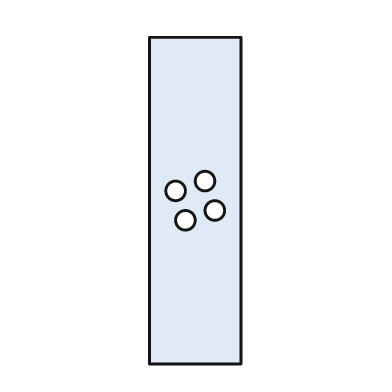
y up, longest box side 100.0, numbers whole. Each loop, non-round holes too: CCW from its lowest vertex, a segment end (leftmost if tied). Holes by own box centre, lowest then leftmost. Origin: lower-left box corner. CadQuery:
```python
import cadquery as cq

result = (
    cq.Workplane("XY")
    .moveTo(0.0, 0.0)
    .lineTo(28.0, 0.0)
    .lineTo(28.0, 100.0)
    .lineTo(0.0, 100.0)
    .close()
    .moveTo(11.0, 44.0)
    .circle(3.0)
    .moveTo(20.0, 47.0)
    .circle(3.0)
    .moveTo(8.0, 53.0)
    .circle(3.0)
    .moveTo(17.0, 56.0)
    .circle(3.0)
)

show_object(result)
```